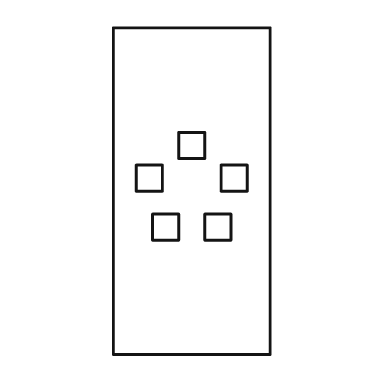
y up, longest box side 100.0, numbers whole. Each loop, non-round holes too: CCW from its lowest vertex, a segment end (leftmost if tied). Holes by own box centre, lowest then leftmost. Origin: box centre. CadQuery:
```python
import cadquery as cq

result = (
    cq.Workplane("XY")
    .moveTo(-24.0, -50.0)
    .lineTo(24.0, -50.0)
    .lineTo(24.0, 50.0)
    .lineTo(-24.0, 50.0)
    .close()
    .moveTo(-12.0, -15.0)
    .lineTo(-4.0, -15.0)
    .lineTo(-4.0, -7.0)
    .lineTo(-12.0, -7.0)
    .close()
    .moveTo(4.0, -15.0)
    .lineTo(12.0, -15.0)
    .lineTo(12.0, -7.0)
    .lineTo(4.0, -7.0)
    .close()
    .moveTo(-17.0, 0.0)
    .lineTo(-9.0, 0.0)
    .lineTo(-9.0, 8.0)
    .lineTo(-17.0, 8.0)
    .close()
    .moveTo(9.0, 0.0)
    .lineTo(17.0, 0.0)
    .lineTo(17.0, 8.0)
    .lineTo(9.0, 8.0)
    .close()
    .moveTo(-4.0, 10.0)
    .lineTo(4.0, 10.0)
    .lineTo(4.0, 18.0)
    .lineTo(-4.0, 18.0)
    .close()
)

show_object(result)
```